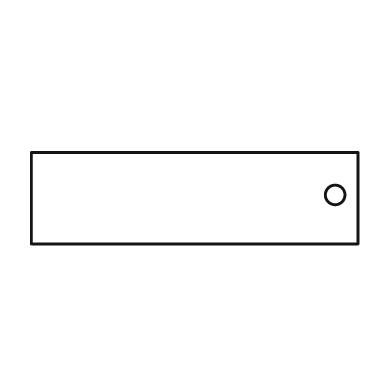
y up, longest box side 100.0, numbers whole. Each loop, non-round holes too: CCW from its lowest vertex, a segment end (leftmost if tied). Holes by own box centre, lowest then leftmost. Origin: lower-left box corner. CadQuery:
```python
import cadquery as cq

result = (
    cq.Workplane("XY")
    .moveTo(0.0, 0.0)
    .lineTo(100.0, 0.0)
    .lineTo(100.0, 28.0)
    .lineTo(0.0, 28.0)
    .close()
    .moveTo(93.0, 15.0)
    .circle(3.0)
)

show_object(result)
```